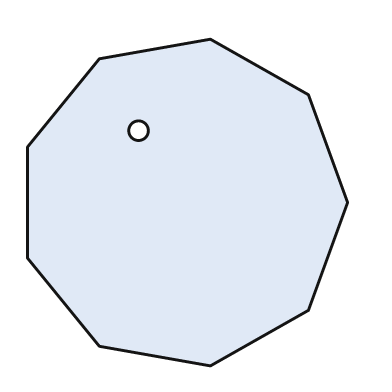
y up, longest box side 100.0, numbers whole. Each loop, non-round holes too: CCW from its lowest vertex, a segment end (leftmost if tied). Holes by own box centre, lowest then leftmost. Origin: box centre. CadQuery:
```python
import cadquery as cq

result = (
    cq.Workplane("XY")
    .moveTo(7.0, -50.0)
    .lineTo(37.0, -33.0)
    .lineTo(49.0, 0.0)
    .lineTo(37.0, 33.0)
    .lineTo(7.0, 50.0)
    .lineTo(-27.0, 44.0)
    .lineTo(-49.0, 17.0)
    .lineTo(-49.0, -17.0)
    .lineTo(-27.0, -44.0)
    .close()
    .moveTo(-15.0, 22.0)
    .circle(3.0)
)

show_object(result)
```